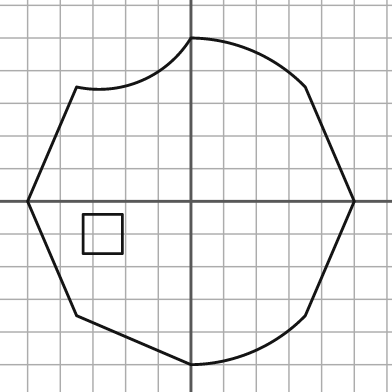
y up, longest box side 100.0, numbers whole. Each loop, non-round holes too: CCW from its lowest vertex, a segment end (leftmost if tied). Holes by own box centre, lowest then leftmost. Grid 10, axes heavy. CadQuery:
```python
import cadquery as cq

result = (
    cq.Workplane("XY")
    .moveTo(0.0, -50.0)
    .threePointArc((19.0, -46.0), (35.0, -35.0))
    .lineTo(50.0, 0.0)
    .lineTo(35.0, 35.0)
    .threePointArc((19.0, 46.0), (0.0, 50.0))
    .threePointArc((-15.0, 37.0), (-35.0, 35.0))
    .lineTo(-50.0, 0.0)
    .lineTo(-35.0, -35.0)
    .close()
    .moveTo(-33.0, -16.0)
    .lineTo(-21.0, -16.0)
    .lineTo(-21.0, -4.0)
    .lineTo(-33.0, -4.0)
    .close()
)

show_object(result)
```